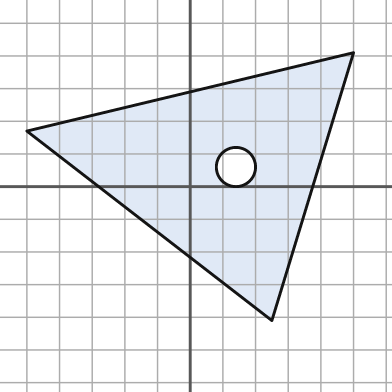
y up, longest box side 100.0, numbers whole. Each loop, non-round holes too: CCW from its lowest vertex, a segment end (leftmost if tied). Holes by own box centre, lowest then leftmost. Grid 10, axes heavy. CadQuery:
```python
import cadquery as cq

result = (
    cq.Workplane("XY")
    .moveTo(25.0, -41.0)
    .lineTo(50.0, 41.0)
    .lineTo(-50.0, 17.0)
    .close()
    .moveTo(14.0, 6.0)
    .circle(6.0)
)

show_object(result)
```